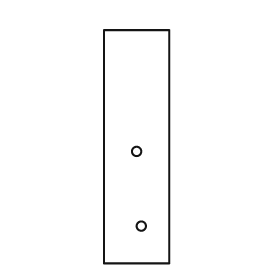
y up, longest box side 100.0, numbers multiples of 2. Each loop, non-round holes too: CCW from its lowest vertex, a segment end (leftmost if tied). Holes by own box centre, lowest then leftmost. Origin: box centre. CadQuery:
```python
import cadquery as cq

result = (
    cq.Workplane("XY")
    .moveTo(-14.0, -50.0)
    .lineTo(14.0, -50.0)
    .lineTo(14.0, 50.0)
    .lineTo(-14.0, 50.0)
    .close()
    .moveTo(2.0, -34.0)
    .circle(2.0)
    .moveTo(0.0, -2.0)
    .circle(2.0)
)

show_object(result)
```